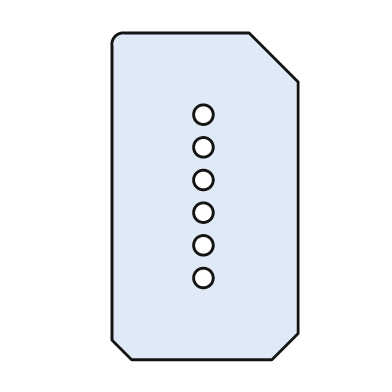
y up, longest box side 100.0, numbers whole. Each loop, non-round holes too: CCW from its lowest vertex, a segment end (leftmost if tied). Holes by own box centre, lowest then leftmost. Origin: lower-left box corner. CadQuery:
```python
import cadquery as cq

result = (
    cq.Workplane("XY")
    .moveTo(6.0, 0.0)
    .lineTo(49.0, 0.0)
    .lineTo(57.0, 8.0)
    .lineTo(57.0, 85.0)
    .lineTo(42.0, 100.0)
    .lineTo(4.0, 100.0)
    .threePointArc((1.0, 99.0), (0.0, 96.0))
    .lineTo(0.0, 6.0)
    .close()
    .moveTo(28.0, 25.0)
    .circle(3.0)
    .moveTo(28.0, 35.0)
    .circle(3.0)
    .moveTo(28.0, 45.0)
    .circle(3.0)
    .moveTo(28.0, 55.0)
    .circle(3.0)
    .moveTo(28.0, 65.0)
    .circle(3.0)
    .moveTo(28.0, 75.0)
    .circle(3.0)
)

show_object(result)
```